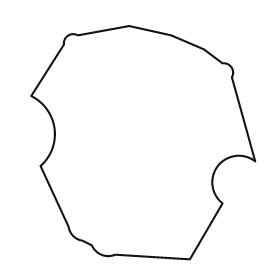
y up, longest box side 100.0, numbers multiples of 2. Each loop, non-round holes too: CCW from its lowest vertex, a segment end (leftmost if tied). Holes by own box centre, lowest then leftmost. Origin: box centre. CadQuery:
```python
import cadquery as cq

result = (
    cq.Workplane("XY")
    .moveTo(20.0, -50.0)
    .lineTo(34.0, -26.0)
    .threePointArc((32.0, -10.0), (48.0, -8.0))
    .lineTo(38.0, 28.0)
    .threePointArc((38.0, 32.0), (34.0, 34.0))
    .lineTo(26.0, 40.0)
    .lineTo(12.0, 46.0)
    .lineTo(-6.0, 50.0)
    .lineTo(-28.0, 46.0)
    .threePointArc((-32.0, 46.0), (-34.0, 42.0))
    .lineTo(-48.0, 20.0)
    .threePointArc((-38.0, 6.0), (-44.0, -10.0))
    .lineTo(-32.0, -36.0)
    .threePointArc((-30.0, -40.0), (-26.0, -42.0))
    .lineTo(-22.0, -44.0)
    .threePointArc((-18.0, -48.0), (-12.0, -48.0))
    .close()
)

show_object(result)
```